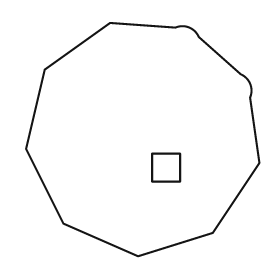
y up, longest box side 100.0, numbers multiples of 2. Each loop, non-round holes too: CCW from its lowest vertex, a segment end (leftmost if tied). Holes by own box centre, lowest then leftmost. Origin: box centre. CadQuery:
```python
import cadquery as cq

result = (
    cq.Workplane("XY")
    .moveTo(-2.0, -50.0)
    .lineTo(30.0, -40.0)
    .lineTo(50.0, -10.0)
    .lineTo(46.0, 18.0)
    .threePointArc((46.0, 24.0), (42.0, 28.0))
    .lineTo(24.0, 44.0)
    .threePointArc((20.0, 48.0), (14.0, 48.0))
    .lineTo(-14.0, 50.0)
    .lineTo(-42.0, 30.0)
    .lineTo(-50.0, -4.0)
    .lineTo(-34.0, -36.0)
    .close()
    .moveTo(4.0, -18.0)
    .lineTo(16.0, -18.0)
    .lineTo(16.0, -6.0)
    .lineTo(4.0, -6.0)
    .close()
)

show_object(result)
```